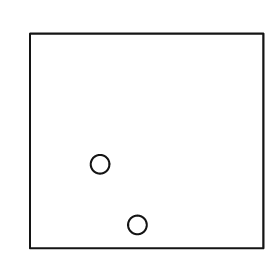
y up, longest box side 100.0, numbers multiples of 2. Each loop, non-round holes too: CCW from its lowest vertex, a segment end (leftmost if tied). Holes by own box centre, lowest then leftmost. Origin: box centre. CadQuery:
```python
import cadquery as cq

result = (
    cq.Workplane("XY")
    .moveTo(-50.0, -46.0)
    .lineTo(50.0, -46.0)
    .lineTo(50.0, 46.0)
    .lineTo(-50.0, 46.0)
    .close()
    .moveTo(-4.0, -36.0)
    .circle(4.0)
    .moveTo(-20.0, -10.0)
    .circle(4.0)
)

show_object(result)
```